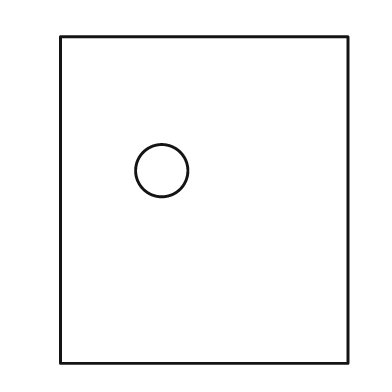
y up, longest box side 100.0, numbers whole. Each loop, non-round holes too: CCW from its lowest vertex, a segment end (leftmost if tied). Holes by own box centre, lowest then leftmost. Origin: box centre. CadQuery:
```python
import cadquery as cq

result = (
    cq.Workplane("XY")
    .moveTo(-44.0, -50.0)
    .lineTo(44.0, -50.0)
    .lineTo(44.0, 50.0)
    .lineTo(-44.0, 50.0)
    .close()
    .moveTo(-13.0, 9.0)
    .circle(8.0)
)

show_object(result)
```